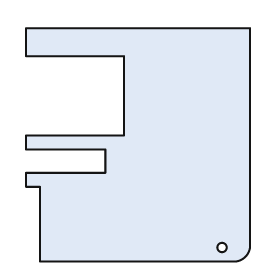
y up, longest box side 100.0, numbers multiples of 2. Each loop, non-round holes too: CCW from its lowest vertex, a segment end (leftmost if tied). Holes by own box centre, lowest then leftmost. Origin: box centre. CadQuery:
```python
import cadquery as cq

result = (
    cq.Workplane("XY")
    .moveTo(-42.0, -50.0)
    .lineTo(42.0, -50.0)
    .threePointArc((46.0, -48.0), (48.0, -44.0))
    .lineTo(48.0, 50.0)
    .lineTo(-48.0, 50.0)
    .lineTo(-48.0, 38.0)
    .lineTo(-6.0, 38.0)
    .lineTo(-6.0, 4.0)
    .lineTo(-48.0, 4.0)
    .lineTo(-48.0, -2.0)
    .lineTo(-14.0, -2.0)
    .lineTo(-14.0, -12.0)
    .lineTo(-48.0, -12.0)
    .lineTo(-48.0, -18.0)
    .lineTo(-42.0, -18.0)
    .close()
    .moveTo(36.0, -44.0)
    .circle(2.0)
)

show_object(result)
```